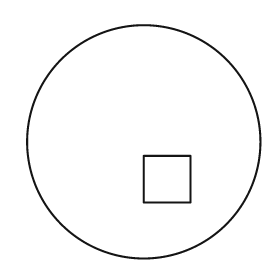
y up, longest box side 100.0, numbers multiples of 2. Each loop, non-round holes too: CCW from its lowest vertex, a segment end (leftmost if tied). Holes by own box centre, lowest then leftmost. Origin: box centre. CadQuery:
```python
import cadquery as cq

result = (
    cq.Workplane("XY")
    .moveTo(0.0, 0.0)
    .circle(50.0)
    .moveTo(0.0, -26.0)
    .lineTo(20.0, -26.0)
    .lineTo(20.0, -6.0)
    .lineTo(0.0, -6.0)
    .close()
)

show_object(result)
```